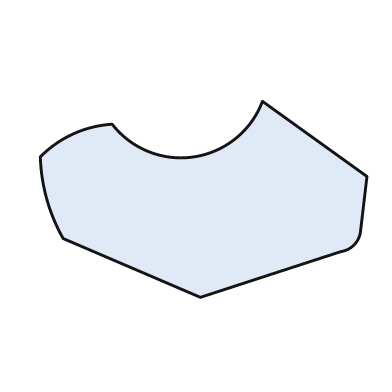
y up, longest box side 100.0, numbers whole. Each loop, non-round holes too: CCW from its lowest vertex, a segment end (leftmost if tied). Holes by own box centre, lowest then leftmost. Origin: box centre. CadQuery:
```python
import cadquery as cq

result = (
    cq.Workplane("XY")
    .moveTo(-1.0, -30.0)
    .lineTo(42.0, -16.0)
    .threePointArc((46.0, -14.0), (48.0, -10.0))
    .lineTo(50.0, 7.0)
    .lineTo(18.0, 30.0)
    .threePointArc((-3.0, 13.0), (-28.0, 23.0))
    .threePointArc((-40.0, 20.0), (-50.0, 13.0))
    .threePointArc((-48.0, 0.0), (-43.0, -12.0))
    .close()
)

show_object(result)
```